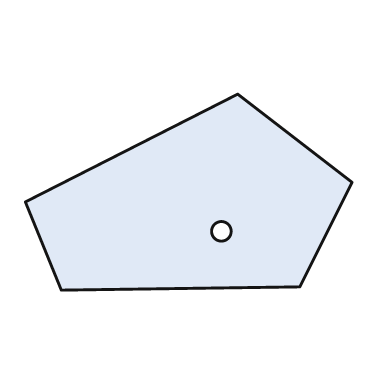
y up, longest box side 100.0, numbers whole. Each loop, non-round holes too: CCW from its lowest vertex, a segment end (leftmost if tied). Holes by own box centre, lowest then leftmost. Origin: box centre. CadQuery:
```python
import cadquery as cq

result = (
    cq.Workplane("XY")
    .moveTo(-39.0, -30.0)
    .lineTo(34.0, -29.0)
    .lineTo(50.0, 3.0)
    .lineTo(15.0, 30.0)
    .lineTo(-50.0, -3.0)
    .close()
    .moveTo(10.0, -12.0)
    .circle(3.0)
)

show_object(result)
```